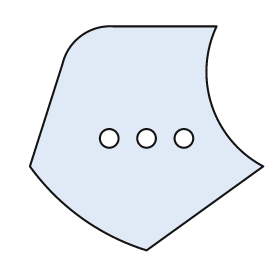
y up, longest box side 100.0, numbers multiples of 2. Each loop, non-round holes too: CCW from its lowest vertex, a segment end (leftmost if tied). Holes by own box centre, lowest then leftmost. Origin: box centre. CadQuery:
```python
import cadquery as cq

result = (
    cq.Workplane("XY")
    .moveTo(0.0, -48.0)
    .lineTo(50.0, -12.0)
    .threePointArc((28.0, 14.0), (30.0, 48.0))
    .lineTo(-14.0, 48.0)
    .threePointArc((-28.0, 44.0), (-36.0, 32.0))
    .lineTo(-50.0, -12.0)
    .threePointArc((-28.0, -34.0), (0.0, -48.0))
    .close()
    .moveTo(-16.0, 0.0)
    .circle(4.0)
    .moveTo(0.0, 0.0)
    .circle(4.0)
    .moveTo(16.0, 0.0)
    .circle(4.0)
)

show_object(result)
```